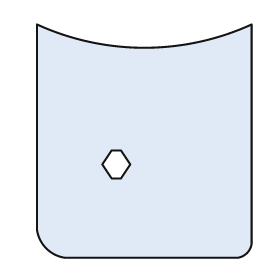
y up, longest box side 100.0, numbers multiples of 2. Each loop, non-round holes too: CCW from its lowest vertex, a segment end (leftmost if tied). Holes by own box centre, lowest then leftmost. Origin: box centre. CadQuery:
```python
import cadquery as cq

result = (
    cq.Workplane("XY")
    .moveTo(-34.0, -50.0)
    .lineTo(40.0, -50.0)
    .threePointArc((44.0, -48.0), (46.0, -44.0))
    .lineTo(46.0, 50.0)
    .threePointArc((0.0, 40.0), (-46.0, 50.0))
    .lineTo(-46.0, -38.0)
    .threePointArc((-42.0, -46.0), (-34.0, -50.0))
    .close()
    .moveTo(-14.0, -16.0)
    .lineTo(-10.0, -16.0)
    .lineTo(-6.0, -10.0)
    .lineTo(-10.0, -4.0)
    .lineTo(-14.0, -4.0)
    .lineTo(-18.0, -10.0)
    .close()
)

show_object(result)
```